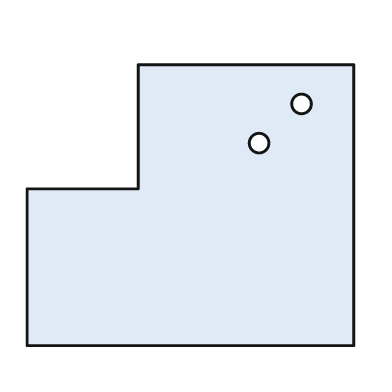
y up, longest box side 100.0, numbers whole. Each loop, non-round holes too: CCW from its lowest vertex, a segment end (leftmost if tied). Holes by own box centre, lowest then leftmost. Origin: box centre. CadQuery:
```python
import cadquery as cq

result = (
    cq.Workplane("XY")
    .moveTo(-50.0, -43.0)
    .lineTo(50.0, -43.0)
    .lineTo(50.0, 43.0)
    .lineTo(-16.0, 43.0)
    .lineTo(-16.0, 5.0)
    .lineTo(-50.0, 5.0)
    .close()
    .moveTo(21.0, 19.0)
    .circle(3.0)
    .moveTo(34.0, 31.0)
    .circle(3.0)
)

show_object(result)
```